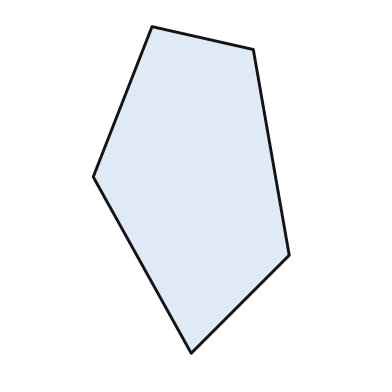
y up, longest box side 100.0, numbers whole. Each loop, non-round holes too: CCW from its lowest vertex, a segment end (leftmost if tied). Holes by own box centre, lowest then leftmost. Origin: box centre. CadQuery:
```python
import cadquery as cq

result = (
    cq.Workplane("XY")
    .moveTo(0.0, -50.0)
    .lineTo(30.0, -20.0)
    .lineTo(19.0, 43.0)
    .lineTo(-12.0, 50.0)
    .lineTo(-30.0, 4.0)
    .close()
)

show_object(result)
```